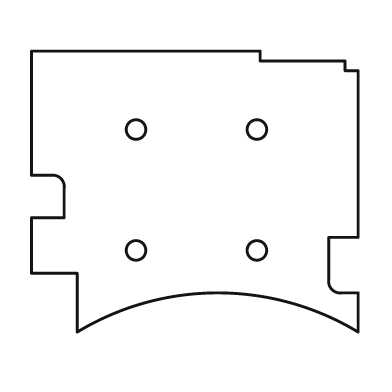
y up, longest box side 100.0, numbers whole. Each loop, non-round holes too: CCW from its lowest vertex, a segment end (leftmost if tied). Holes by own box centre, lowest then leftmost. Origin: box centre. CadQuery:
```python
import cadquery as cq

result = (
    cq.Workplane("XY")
    .moveTo(-36.0, -43.0)
    .threePointArc((7.0, -31.0), (50.0, -43.0))
    .lineTo(50.0, -31.0)
    .lineTo(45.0, -31.0)
    .threePointArc((42.0, -30.0), (41.0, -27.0))
    .lineTo(41.0, -14.0)
    .lineTo(50.0, -14.0)
    .lineTo(50.0, 37.0)
    .lineTo(46.0, 37.0)
    .lineTo(46.0, 40.0)
    .lineTo(20.0, 40.0)
    .lineTo(20.0, 43.0)
    .lineTo(-50.0, 43.0)
    .lineTo(-50.0, 5.0)
    .lineTo(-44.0, 5.0)
    .threePointArc((-41.0, 4.0), (-40.0, 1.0))
    .lineTo(-40.0, -8.0)
    .lineTo(-50.0, -8.0)
    .lineTo(-50.0, -25.0)
    .lineTo(-36.0, -25.0)
    .close()
    .moveTo(-18.0, -18.0)
    .circle(3.0)
    .moveTo(19.0, -18.0)
    .circle(3.0)
    .moveTo(-18.0, 19.0)
    .circle(3.0)
    .moveTo(19.0, 19.0)
    .circle(3.0)
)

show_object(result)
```